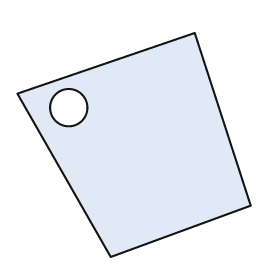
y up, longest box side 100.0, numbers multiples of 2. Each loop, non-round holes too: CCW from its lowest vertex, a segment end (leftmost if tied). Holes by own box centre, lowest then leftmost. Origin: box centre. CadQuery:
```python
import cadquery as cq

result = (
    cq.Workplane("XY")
    .moveTo(-10.0, -48.0)
    .lineTo(50.0, -26.0)
    .lineTo(26.0, 48.0)
    .lineTo(-50.0, 22.0)
    .close()
    .moveTo(-28.0, 16.0)
    .circle(8.0)
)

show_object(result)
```